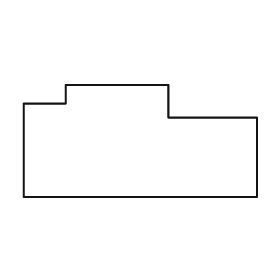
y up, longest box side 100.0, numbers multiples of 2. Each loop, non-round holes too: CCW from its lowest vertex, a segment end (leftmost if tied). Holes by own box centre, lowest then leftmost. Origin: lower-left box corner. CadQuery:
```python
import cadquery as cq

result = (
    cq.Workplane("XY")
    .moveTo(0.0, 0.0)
    .lineTo(100.0, 0.0)
    .lineTo(100.0, 34.0)
    .lineTo(62.0, 34.0)
    .lineTo(62.0, 48.0)
    .lineTo(18.0, 48.0)
    .lineTo(18.0, 40.0)
    .lineTo(0.0, 40.0)
    .close()
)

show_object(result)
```